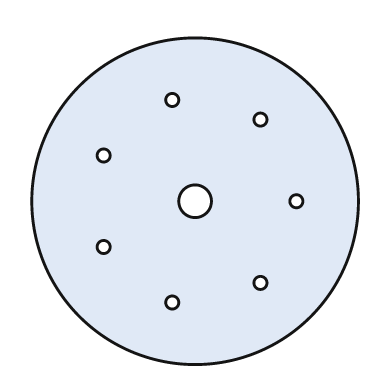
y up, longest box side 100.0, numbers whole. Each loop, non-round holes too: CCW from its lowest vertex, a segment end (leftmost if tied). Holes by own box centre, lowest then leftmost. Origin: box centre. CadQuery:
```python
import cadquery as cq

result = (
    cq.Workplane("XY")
    .moveTo(0.0, 0.0)
    .circle(50.0)
    .moveTo(-7.0, -31.0)
    .circle(2.0)
    .moveTo(20.0, -25.0)
    .circle(2.0)
    .moveTo(-28.0, -14.0)
    .circle(2.0)
    .moveTo(0.0, 0.0)
    .circle(5.0)
    .moveTo(31.0, 0.0)
    .circle(2.0)
    .moveTo(-28.0, 14.0)
    .circle(2.0)
    .moveTo(20.0, 25.0)
    .circle(2.0)
    .moveTo(-7.0, 31.0)
    .circle(2.0)
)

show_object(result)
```